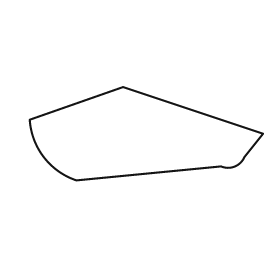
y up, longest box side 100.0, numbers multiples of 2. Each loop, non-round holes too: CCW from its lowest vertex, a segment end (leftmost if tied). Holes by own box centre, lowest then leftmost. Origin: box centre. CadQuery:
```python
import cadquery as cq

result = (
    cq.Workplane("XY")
    .moveTo(-30.0, -20.0)
    .lineTo(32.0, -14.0)
    .threePointArc((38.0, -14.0), (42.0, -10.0))
    .lineTo(50.0, 0.0)
    .lineTo(-10.0, 20.0)
    .lineTo(-50.0, 6.0)
    .threePointArc((-44.0, -10.0), (-30.0, -20.0))
    .close()
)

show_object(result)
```